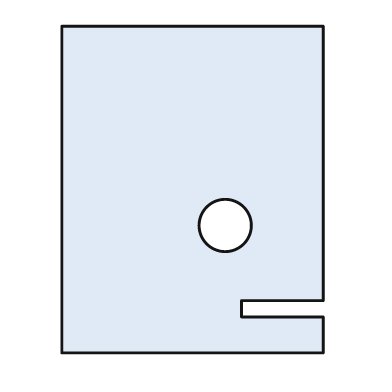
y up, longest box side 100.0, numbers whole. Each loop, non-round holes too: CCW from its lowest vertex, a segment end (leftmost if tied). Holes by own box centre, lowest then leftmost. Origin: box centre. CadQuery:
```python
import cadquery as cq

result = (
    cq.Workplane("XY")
    .moveTo(-40.0, -50.0)
    .lineTo(40.0, -50.0)
    .lineTo(40.0, -39.0)
    .lineTo(15.0, -39.0)
    .lineTo(15.0, -34.0)
    .lineTo(40.0, -34.0)
    .lineTo(40.0, 50.0)
    .lineTo(-40.0, 50.0)
    .close()
    .moveTo(10.0, -11.0)
    .circle(8.0)
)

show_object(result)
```